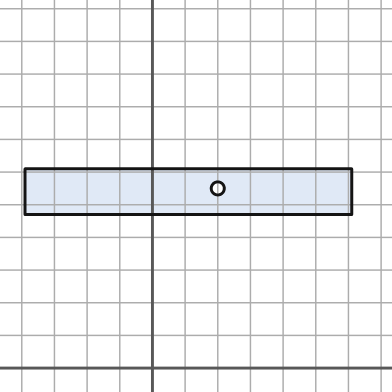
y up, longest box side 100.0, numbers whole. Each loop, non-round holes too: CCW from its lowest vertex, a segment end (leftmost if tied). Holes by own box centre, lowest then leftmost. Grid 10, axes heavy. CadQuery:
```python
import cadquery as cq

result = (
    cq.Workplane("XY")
    .moveTo(-39.0, 47.0)
    .lineTo(61.0, 47.0)
    .lineTo(61.0, 61.0)
    .lineTo(-39.0, 61.0)
    .close()
    .moveTo(20.0, 55.0)
    .circle(2.0)
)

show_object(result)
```